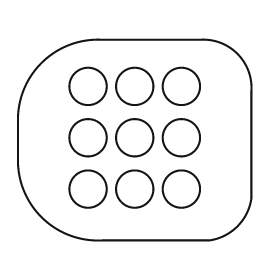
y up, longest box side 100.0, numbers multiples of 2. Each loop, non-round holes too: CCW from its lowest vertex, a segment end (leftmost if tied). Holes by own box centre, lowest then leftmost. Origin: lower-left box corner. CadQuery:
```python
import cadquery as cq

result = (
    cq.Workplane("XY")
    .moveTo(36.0, 0.0)
    .lineTo(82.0, 0.0)
    .threePointArc((94.0, 6.0), (100.0, 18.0))
    .lineTo(100.0, 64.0)
    .threePointArc((94.0, 80.0), (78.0, 86.0))
    .lineTo(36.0, 86.0)
    .threePointArc((10.0, 76.0), (0.0, 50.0))
    .lineTo(0.0, 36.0)
    .threePointArc((10.0, 10.0), (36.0, 0.0))
    .close()
    .moveTo(30.0, 22.0)
    .circle(8.0)
    .moveTo(50.0, 22.0)
    .circle(8.0)
    .moveTo(70.0, 22.0)
    .circle(8.0)
    .moveTo(30.0, 44.0)
    .circle(8.0)
    .moveTo(50.0, 44.0)
    .circle(8.0)
    .moveTo(70.0, 44.0)
    .circle(8.0)
    .moveTo(30.0, 66.0)
    .circle(8.0)
    .moveTo(50.0, 66.0)
    .circle(8.0)
    .moveTo(70.0, 66.0)
    .circle(8.0)
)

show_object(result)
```